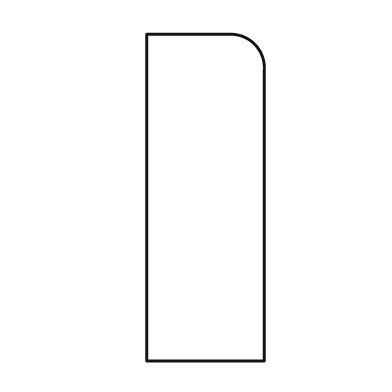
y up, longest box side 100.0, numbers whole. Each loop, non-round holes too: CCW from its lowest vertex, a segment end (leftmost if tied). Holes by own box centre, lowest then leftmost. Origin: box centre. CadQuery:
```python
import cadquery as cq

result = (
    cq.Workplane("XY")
    .moveTo(-18.0, -50.0)
    .lineTo(18.0, -50.0)
    .lineTo(18.0, 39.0)
    .threePointArc((15.0, 47.0), (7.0, 50.0))
    .lineTo(-18.0, 50.0)
    .close()
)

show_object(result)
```